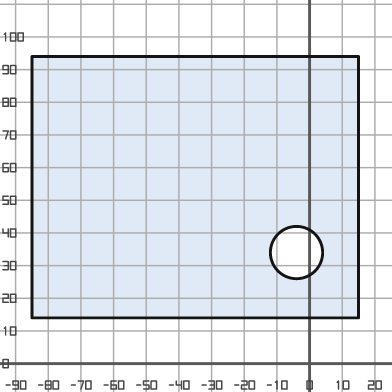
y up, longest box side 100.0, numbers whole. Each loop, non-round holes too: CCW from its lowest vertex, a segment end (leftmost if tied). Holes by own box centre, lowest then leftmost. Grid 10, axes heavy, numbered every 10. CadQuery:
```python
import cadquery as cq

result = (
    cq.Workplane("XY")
    .moveTo(-85.0, 14.0)
    .lineTo(15.0, 14.0)
    .lineTo(15.0, 94.0)
    .lineTo(-85.0, 94.0)
    .close()
    .moveTo(-4.0, 34.0)
    .circle(8.0)
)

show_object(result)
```